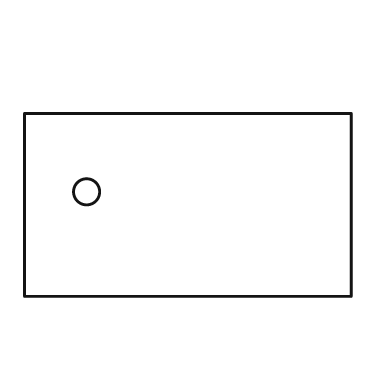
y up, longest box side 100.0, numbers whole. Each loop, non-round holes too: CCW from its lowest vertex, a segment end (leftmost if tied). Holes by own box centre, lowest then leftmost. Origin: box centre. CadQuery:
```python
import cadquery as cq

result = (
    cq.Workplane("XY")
    .moveTo(-50.0, -28.0)
    .lineTo(50.0, -28.0)
    .lineTo(50.0, 28.0)
    .lineTo(-50.0, 28.0)
    .close()
    .moveTo(-31.0, 4.0)
    .circle(4.0)
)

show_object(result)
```